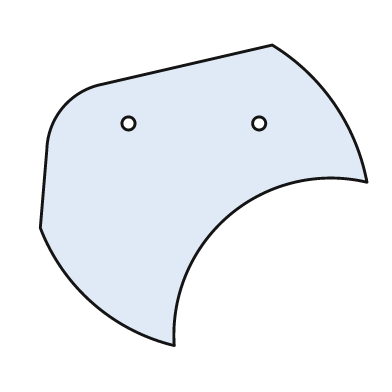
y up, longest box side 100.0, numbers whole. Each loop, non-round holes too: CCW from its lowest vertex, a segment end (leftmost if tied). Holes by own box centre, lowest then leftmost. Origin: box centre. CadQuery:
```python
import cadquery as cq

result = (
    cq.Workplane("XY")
    .moveTo(-9.0, -46.0)
    .threePointArc((8.0, -6.0), (50.0, 4.0))
    .threePointArc((40.0, 28.0), (21.0, 46.0))
    .lineTo(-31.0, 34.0)
    .threePointArc((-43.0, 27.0), (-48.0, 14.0))
    .lineTo(-50.0, -10.0)
    .threePointArc((-34.0, -33.0), (-9.0, -46.0))
    .close()
    .moveTo(-23.0, 22.0)
    .circle(2.0)
    .moveTo(17.0, 22.0)
    .circle(2.0)
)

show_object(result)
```